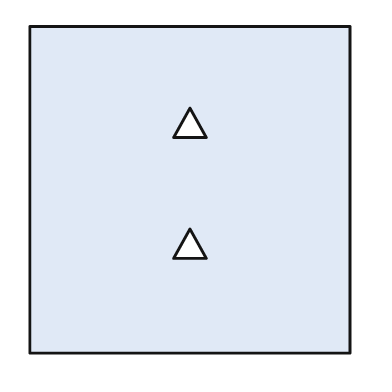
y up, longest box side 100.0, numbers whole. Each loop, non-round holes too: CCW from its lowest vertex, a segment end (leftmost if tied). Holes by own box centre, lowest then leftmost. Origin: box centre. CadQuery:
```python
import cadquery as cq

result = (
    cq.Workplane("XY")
    .moveTo(-49.0, -50.0)
    .lineTo(49.0, -50.0)
    .lineTo(49.0, 50.0)
    .lineTo(-49.0, 50.0)
    .close()
    .moveTo(-5.0, -21.0)
    .lineTo(5.0, -21.0)
    .lineTo(0.0, -12.0)
    .close()
    .moveTo(-5.0, 16.0)
    .lineTo(5.0, 16.0)
    .lineTo(0.0, 25.0)
    .close()
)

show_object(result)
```